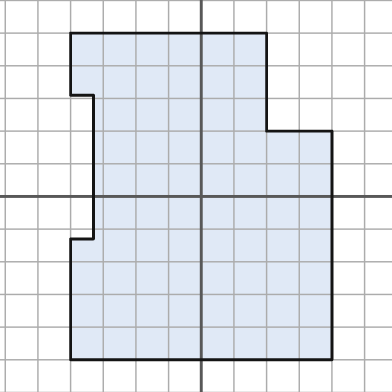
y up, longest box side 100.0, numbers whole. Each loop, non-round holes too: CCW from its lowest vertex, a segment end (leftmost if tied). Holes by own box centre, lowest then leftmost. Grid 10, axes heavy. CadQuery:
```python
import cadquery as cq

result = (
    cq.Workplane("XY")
    .moveTo(-40.0, -50.0)
    .lineTo(40.0, -50.0)
    .lineTo(40.0, 20.0)
    .lineTo(20.0, 20.0)
    .lineTo(20.0, 50.0)
    .lineTo(-40.0, 50.0)
    .lineTo(-40.0, 31.0)
    .lineTo(-33.0, 31.0)
    .lineTo(-33.0, -13.0)
    .lineTo(-40.0, -13.0)
    .close()
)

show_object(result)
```